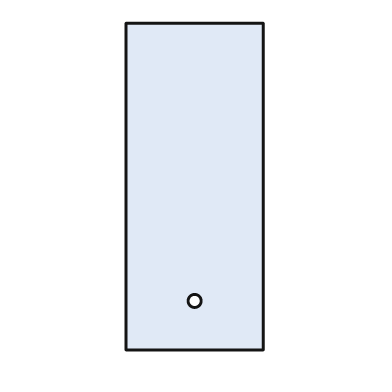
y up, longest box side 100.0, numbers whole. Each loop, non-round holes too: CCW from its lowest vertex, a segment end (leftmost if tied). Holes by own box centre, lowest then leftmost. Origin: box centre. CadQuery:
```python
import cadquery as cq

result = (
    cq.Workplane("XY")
    .moveTo(-21.0, -50.0)
    .lineTo(21.0, -50.0)
    .lineTo(21.0, 50.0)
    .lineTo(-21.0, 50.0)
    .close()
    .moveTo(0.0, -35.0)
    .circle(2.0)
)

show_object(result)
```